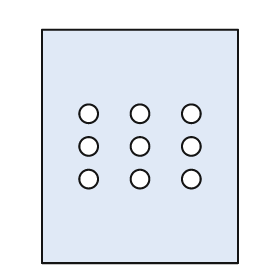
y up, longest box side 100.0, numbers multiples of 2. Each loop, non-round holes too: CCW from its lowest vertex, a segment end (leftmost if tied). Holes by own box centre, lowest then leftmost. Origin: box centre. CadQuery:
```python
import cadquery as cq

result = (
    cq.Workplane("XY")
    .moveTo(-42.0, -50.0)
    .lineTo(42.0, -50.0)
    .lineTo(42.0, 50.0)
    .lineTo(-42.0, 50.0)
    .close()
    .moveTo(-22.0, -14.0)
    .circle(4.0)
    .moveTo(0.0, -14.0)
    .circle(4.0)
    .moveTo(22.0, -14.0)
    .circle(4.0)
    .moveTo(-22.0, 0.0)
    .circle(4.0)
    .moveTo(0.0, 0.0)
    .circle(4.0)
    .moveTo(22.0, 0.0)
    .circle(4.0)
    .moveTo(-22.0, 14.0)
    .circle(4.0)
    .moveTo(0.0, 14.0)
    .circle(4.0)
    .moveTo(22.0, 14.0)
    .circle(4.0)
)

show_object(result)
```